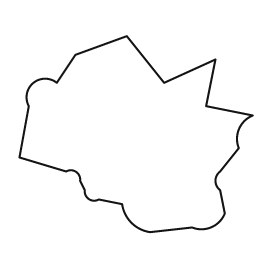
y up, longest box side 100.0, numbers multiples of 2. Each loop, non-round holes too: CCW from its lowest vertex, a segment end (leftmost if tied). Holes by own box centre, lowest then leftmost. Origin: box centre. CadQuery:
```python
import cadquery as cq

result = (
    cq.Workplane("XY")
    .moveTo(6.0, -42.0)
    .lineTo(24.0, -40.0)
    .threePointArc((32.0, -40.0), (38.0, -34.0))
    .lineTo(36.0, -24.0)
    .threePointArc((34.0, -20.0), (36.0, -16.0))
    .lineTo(44.0, -6.0)
    .threePointArc((44.0, 2.0), (50.0, 8.0))
    .lineTo(30.0, 12.0)
    .lineTo(34.0, 32.0)
    .lineTo(12.0, 22.0)
    .lineTo(-4.0, 42.0)
    .lineTo(-26.0, 34.0)
    .lineTo(-34.0, 22.0)
    .threePointArc((-44.0, 22.0), (-46.0, 12.0))
    .lineTo(-50.0, -10.0)
    .lineTo(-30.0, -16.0)
    .threePointArc((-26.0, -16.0), (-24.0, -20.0))
    .lineTo(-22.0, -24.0)
    .threePointArc((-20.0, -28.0), (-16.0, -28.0))
    .lineTo(-6.0, -30.0)
    .threePointArc((-2.0, -38.0), (6.0, -42.0))
    .close()
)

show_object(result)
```